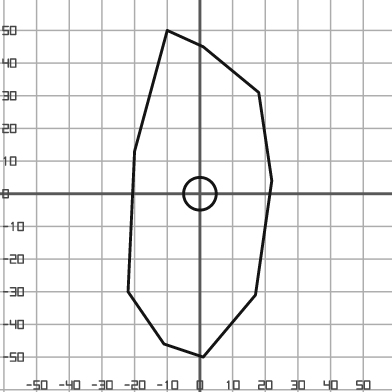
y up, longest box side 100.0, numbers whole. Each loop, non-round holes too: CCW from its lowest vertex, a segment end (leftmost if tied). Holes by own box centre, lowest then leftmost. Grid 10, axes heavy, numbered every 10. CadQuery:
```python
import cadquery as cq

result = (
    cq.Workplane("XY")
    .moveTo(1.0, -50.0)
    .lineTo(17.0, -31.0)
    .lineTo(22.0, 4.0)
    .lineTo(18.0, 31.0)
    .lineTo(1.0, 45.0)
    .lineTo(-10.0, 50.0)
    .lineTo(-20.0, 13.0)
    .lineTo(-22.0, -30.0)
    .lineTo(-11.0, -46.0)
    .close()
    .moveTo(0.0, 0.0)
    .circle(5.0)
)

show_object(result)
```